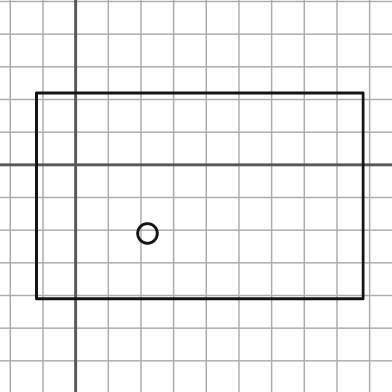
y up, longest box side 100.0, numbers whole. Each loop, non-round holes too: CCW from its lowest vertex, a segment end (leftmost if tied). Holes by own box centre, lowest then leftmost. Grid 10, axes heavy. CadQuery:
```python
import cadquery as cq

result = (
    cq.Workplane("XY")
    .moveTo(-12.0, -41.0)
    .lineTo(88.0, -41.0)
    .lineTo(88.0, 22.0)
    .lineTo(-12.0, 22.0)
    .close()
    .moveTo(22.0, -21.0)
    .circle(3.0)
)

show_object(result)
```